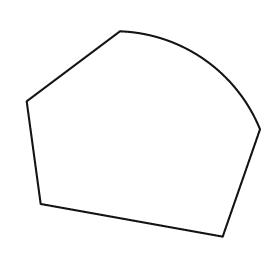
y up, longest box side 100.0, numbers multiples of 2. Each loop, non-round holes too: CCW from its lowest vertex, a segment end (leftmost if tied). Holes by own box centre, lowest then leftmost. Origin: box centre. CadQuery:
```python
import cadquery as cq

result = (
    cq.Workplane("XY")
    .moveTo(34.0, -44.0)
    .lineTo(50.0, 2.0)
    .threePointArc((26.0, 32.0), (-10.0, 44.0))
    .lineTo(-50.0, 14.0)
    .lineTo(-44.0, -30.0)
    .close()
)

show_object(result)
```